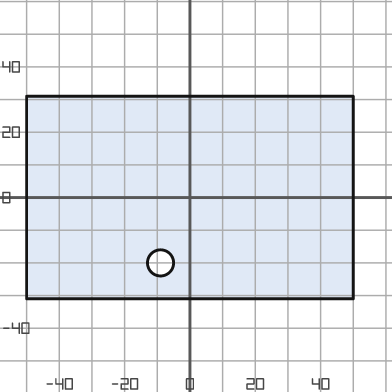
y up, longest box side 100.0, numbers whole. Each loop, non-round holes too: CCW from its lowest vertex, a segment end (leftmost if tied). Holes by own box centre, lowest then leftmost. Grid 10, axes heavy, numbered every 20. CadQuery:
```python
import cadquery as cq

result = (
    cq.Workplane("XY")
    .moveTo(-50.0, -31.0)
    .lineTo(50.0, -31.0)
    .lineTo(50.0, 31.0)
    .lineTo(-50.0, 31.0)
    .close()
    .moveTo(-9.0, -20.0)
    .circle(4.0)
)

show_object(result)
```